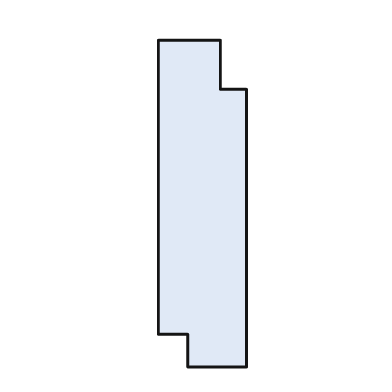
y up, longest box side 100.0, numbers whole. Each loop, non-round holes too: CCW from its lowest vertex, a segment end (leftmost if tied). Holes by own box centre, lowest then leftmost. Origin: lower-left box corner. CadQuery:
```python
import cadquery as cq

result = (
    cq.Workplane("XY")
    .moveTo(9.0, 0.0)
    .lineTo(27.0, 0.0)
    .lineTo(27.0, 85.0)
    .lineTo(19.0, 85.0)
    .lineTo(19.0, 100.0)
    .lineTo(0.0, 100.0)
    .lineTo(0.0, 10.0)
    .lineTo(9.0, 10.0)
    .close()
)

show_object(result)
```